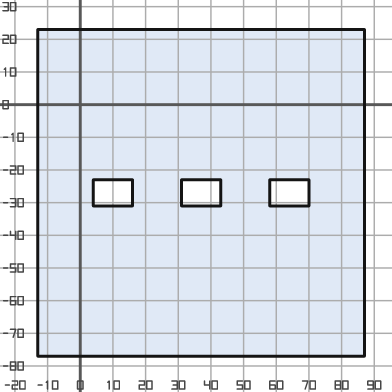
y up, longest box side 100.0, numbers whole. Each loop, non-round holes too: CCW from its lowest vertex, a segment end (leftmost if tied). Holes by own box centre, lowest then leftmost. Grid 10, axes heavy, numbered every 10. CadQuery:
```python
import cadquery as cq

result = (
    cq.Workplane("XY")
    .moveTo(-13.0, -77.0)
    .lineTo(87.0, -77.0)
    .lineTo(87.0, 23.0)
    .lineTo(-13.0, 23.0)
    .close()
    .moveTo(4.0, -31.0)
    .lineTo(16.0, -31.0)
    .lineTo(16.0, -23.0)
    .lineTo(4.0, -23.0)
    .close()
    .moveTo(31.0, -31.0)
    .lineTo(43.0, -31.0)
    .lineTo(43.0, -23.0)
    .lineTo(31.0, -23.0)
    .close()
    .moveTo(58.0, -31.0)
    .lineTo(70.0, -31.0)
    .lineTo(70.0, -23.0)
    .lineTo(58.0, -23.0)
    .close()
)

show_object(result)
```